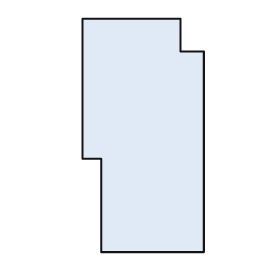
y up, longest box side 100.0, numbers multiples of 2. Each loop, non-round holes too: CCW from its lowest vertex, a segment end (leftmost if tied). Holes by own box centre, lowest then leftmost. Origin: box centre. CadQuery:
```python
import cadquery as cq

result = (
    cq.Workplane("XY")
    .moveTo(-18.0, -50.0)
    .lineTo(26.0, -50.0)
    .lineTo(26.0, 36.0)
    .lineTo(16.0, 36.0)
    .lineTo(16.0, 50.0)
    .lineTo(-26.0, 50.0)
    .lineTo(-26.0, -10.0)
    .lineTo(-18.0, -10.0)
    .close()
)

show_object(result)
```